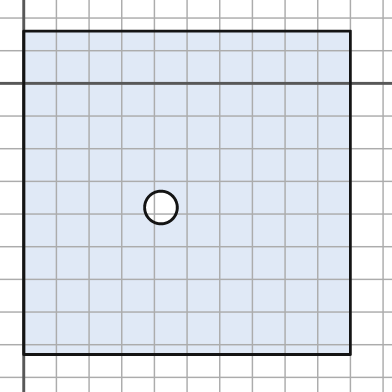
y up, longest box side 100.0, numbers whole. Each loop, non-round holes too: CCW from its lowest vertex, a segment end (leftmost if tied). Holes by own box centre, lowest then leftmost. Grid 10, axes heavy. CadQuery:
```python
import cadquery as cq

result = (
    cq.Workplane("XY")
    .moveTo(0.0, -83.0)
    .lineTo(100.0, -83.0)
    .lineTo(100.0, 16.0)
    .lineTo(0.0, 16.0)
    .close()
    .moveTo(42.0, -38.0)
    .circle(5.0)
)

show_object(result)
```